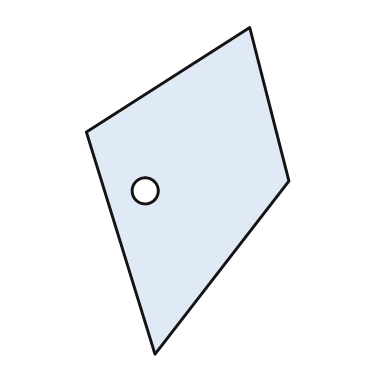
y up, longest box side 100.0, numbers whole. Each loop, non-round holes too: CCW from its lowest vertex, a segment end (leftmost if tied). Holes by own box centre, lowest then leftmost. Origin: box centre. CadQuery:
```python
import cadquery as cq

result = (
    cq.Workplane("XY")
    .moveTo(-10.0, -50.0)
    .lineTo(31.0, 3.0)
    .lineTo(19.0, 50.0)
    .lineTo(-31.0, 18.0)
    .close()
    .moveTo(-13.0, 0.0)
    .circle(4.0)
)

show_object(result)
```